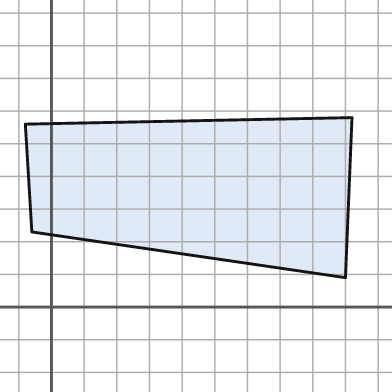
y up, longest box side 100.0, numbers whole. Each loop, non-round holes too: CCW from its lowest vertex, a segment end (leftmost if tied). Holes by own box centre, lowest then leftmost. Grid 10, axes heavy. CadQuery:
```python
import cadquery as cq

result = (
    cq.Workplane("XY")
    .moveTo(90.0, 9.0)
    .lineTo(92.0, 58.0)
    .lineTo(-8.0, 56.0)
    .lineTo(-6.0, 23.0)
    .close()
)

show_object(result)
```